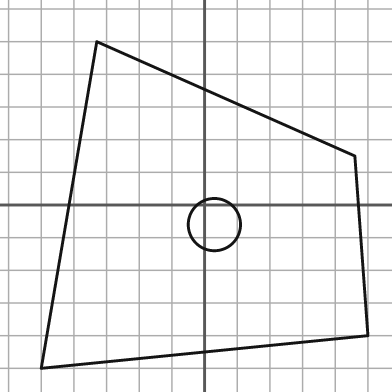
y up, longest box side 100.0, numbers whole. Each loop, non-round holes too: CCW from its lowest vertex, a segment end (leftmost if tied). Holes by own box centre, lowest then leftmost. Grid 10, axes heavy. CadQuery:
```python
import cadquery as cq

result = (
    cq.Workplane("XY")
    .moveTo(-50.0, -50.0)
    .lineTo(50.0, -40.0)
    .lineTo(46.0, 15.0)
    .lineTo(-33.0, 50.0)
    .close()
    .moveTo(3.0, -6.0)
    .circle(8.0)
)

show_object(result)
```